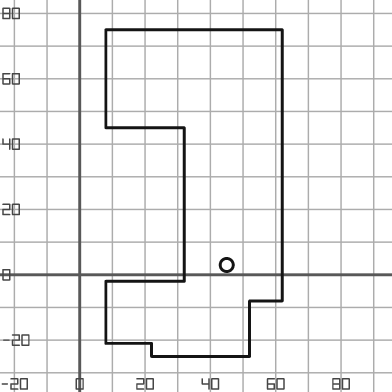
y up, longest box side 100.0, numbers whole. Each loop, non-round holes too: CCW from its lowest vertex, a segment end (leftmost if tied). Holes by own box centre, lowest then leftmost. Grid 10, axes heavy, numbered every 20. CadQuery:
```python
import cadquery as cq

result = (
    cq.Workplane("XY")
    .moveTo(22.0, -25.0)
    .lineTo(52.0, -25.0)
    .lineTo(52.0, -8.0)
    .lineTo(62.0, -8.0)
    .lineTo(62.0, 75.0)
    .lineTo(8.0, 75.0)
    .lineTo(8.0, 45.0)
    .lineTo(32.0, 45.0)
    .lineTo(32.0, -2.0)
    .lineTo(8.0, -2.0)
    .lineTo(8.0, -21.0)
    .lineTo(22.0, -21.0)
    .close()
    .moveTo(45.0, 3.0)
    .circle(2.0)
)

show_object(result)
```